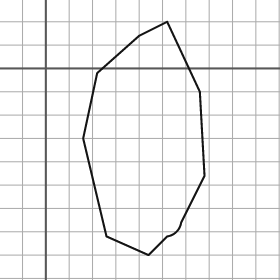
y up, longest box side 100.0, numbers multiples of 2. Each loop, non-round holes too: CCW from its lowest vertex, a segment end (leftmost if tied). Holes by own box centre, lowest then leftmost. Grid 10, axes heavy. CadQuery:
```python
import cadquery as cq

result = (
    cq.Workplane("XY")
    .moveTo(44.0, -80.0)
    .lineTo(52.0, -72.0)
    .threePointArc((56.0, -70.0), (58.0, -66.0))
    .lineTo(68.0, -46.0)
    .lineTo(66.0, -10.0)
    .lineTo(52.0, 20.0)
    .lineTo(40.0, 14.0)
    .lineTo(22.0, -2.0)
    .lineTo(16.0, -30.0)
    .lineTo(26.0, -72.0)
    .close()
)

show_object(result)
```